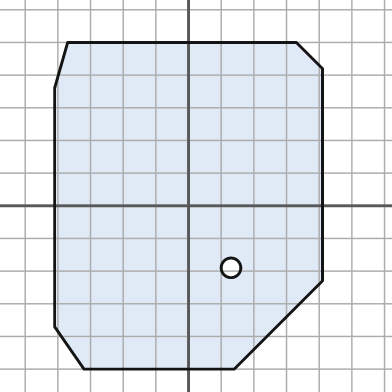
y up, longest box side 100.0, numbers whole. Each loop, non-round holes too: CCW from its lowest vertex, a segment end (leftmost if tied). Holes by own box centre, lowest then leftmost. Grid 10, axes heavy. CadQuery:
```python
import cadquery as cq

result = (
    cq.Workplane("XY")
    .moveTo(-32.0, -50.0)
    .lineTo(14.0, -50.0)
    .lineTo(41.0, -23.0)
    .lineTo(41.0, 42.0)
    .lineTo(33.0, 50.0)
    .lineTo(-37.0, 50.0)
    .lineTo(-41.0, 36.0)
    .lineTo(-41.0, -37.0)
    .close()
    .moveTo(13.0, -19.0)
    .circle(3.0)
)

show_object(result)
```